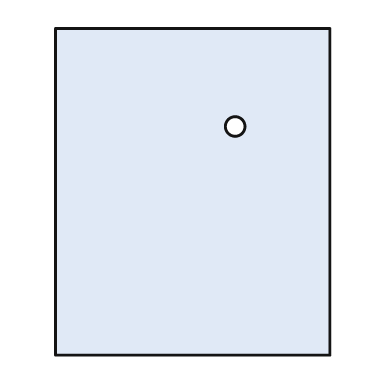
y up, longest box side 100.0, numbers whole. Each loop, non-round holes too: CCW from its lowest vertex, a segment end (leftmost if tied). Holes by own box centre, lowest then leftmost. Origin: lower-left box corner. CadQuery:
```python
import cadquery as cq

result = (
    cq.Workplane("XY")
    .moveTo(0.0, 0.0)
    .lineTo(84.0, 0.0)
    .lineTo(84.0, 100.0)
    .lineTo(0.0, 100.0)
    .close()
    .moveTo(55.0, 70.0)
    .circle(3.0)
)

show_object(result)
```